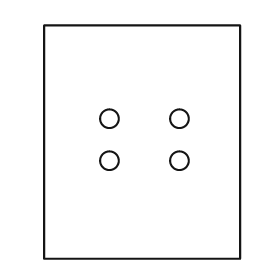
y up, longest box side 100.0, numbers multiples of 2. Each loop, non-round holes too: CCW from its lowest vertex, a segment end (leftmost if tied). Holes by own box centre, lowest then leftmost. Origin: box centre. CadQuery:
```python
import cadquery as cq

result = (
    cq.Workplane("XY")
    .moveTo(-42.0, -50.0)
    .lineTo(42.0, -50.0)
    .lineTo(42.0, 50.0)
    .lineTo(-42.0, 50.0)
    .close()
    .moveTo(-14.0, -8.0)
    .circle(4.0)
    .moveTo(16.0, -8.0)
    .circle(4.0)
    .moveTo(-14.0, 10.0)
    .circle(4.0)
    .moveTo(16.0, 10.0)
    .circle(4.0)
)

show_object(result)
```